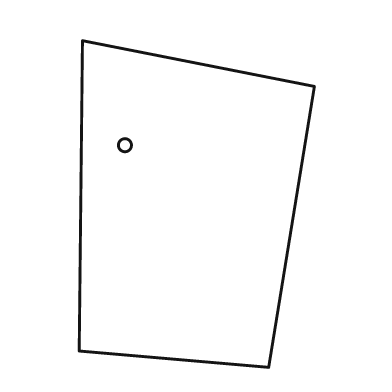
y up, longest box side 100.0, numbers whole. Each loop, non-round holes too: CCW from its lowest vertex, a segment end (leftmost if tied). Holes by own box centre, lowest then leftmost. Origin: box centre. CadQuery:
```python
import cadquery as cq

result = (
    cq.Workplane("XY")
    .moveTo(22.0, -50.0)
    .lineTo(36.0, 36.0)
    .lineTo(-35.0, 50.0)
    .lineTo(-36.0, -45.0)
    .close()
    .moveTo(-22.0, 18.0)
    .circle(2.0)
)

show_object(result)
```